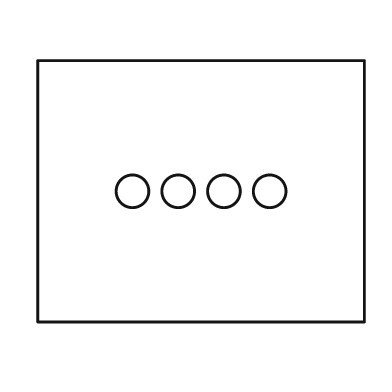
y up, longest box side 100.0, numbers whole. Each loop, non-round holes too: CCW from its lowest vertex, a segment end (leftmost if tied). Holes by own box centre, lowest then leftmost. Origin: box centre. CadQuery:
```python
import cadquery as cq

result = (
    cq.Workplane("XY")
    .moveTo(-50.0, -40.0)
    .lineTo(50.0, -40.0)
    .lineTo(50.0, 40.0)
    .lineTo(-50.0, 40.0)
    .close()
    .moveTo(-21.0, 0.0)
    .circle(5.0)
    .moveTo(-7.0, 0.0)
    .circle(5.0)
    .moveTo(7.0, 0.0)
    .circle(5.0)
    .moveTo(21.0, 0.0)
    .circle(5.0)
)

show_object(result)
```